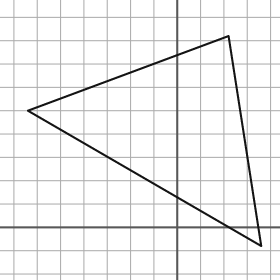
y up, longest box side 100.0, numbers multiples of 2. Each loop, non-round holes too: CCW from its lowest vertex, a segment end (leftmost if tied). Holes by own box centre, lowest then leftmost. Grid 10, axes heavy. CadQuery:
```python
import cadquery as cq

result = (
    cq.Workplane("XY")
    .moveTo(36.0, -8.0)
    .lineTo(22.0, 82.0)
    .lineTo(-64.0, 50.0)
    .close()
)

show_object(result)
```